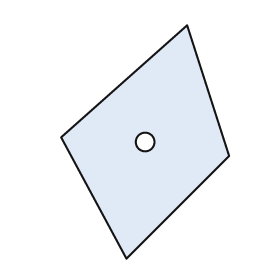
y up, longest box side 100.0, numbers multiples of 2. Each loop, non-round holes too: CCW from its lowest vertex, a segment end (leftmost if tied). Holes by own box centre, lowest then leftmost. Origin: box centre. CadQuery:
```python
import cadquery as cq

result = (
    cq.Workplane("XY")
    .moveTo(-8.0, -50.0)
    .lineTo(36.0, -6.0)
    .lineTo(18.0, 50.0)
    .lineTo(-36.0, 2.0)
    .close()
    .moveTo(0.0, 0.0)
    .circle(4.0)
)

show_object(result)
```